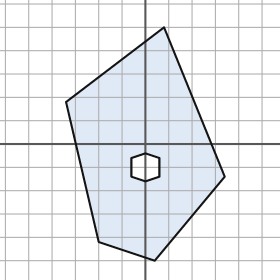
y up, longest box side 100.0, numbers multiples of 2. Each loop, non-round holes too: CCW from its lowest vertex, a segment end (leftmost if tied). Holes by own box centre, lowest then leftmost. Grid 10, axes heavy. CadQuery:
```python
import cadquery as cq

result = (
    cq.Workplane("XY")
    .moveTo(4.0, -50.0)
    .lineTo(34.0, -14.0)
    .lineTo(8.0, 50.0)
    .lineTo(-34.0, 18.0)
    .lineTo(-20.0, -42.0)
    .close()
    .moveTo(0.0, -16.0)
    .lineTo(6.0, -14.0)
    .lineTo(6.0, -6.0)
    .lineTo(0.0, -4.0)
    .lineTo(-6.0, -6.0)
    .lineTo(-6.0, -14.0)
    .close()
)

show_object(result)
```